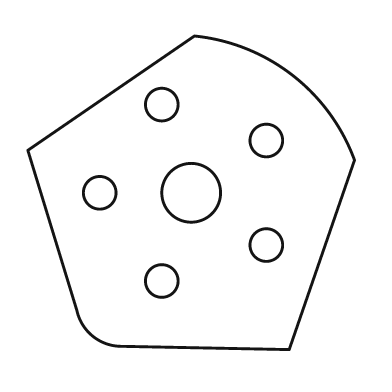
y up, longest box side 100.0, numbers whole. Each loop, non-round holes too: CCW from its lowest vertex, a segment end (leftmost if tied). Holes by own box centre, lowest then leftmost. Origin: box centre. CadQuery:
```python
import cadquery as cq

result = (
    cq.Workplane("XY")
    .moveTo(30.0, -48.0)
    .lineTo(50.0, 10.0)
    .threePointArc((31.0, 36.0), (1.0, 48.0))
    .lineTo(-50.0, 13.0)
    .lineTo(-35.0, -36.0)
    .threePointArc((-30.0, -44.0), (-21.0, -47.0))
    .close()
    .moveTo(-9.0, -27.0)
    .circle(5.0)
    .moveTo(23.0, -16.0)
    .circle(5.0)
    .moveTo(-28.0, 0.0)
    .circle(5.0)
    .moveTo(0.0, 0.0)
    .circle(9.0)
    .moveTo(23.0, 16.0)
    .circle(5.0)
    .moveTo(-9.0, 27.0)
    .circle(5.0)
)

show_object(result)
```